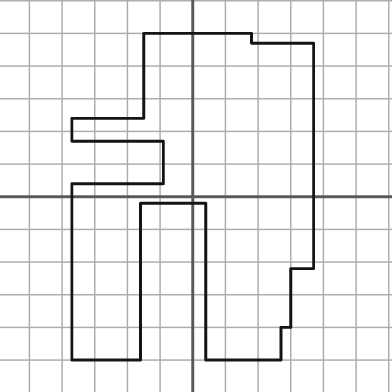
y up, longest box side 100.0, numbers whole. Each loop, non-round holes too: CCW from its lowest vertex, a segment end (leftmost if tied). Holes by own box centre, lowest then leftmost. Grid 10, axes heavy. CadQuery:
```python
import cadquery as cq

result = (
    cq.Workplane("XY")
    .moveTo(-37.0, -50.0)
    .lineTo(-16.0, -50.0)
    .lineTo(-16.0, -2.0)
    .lineTo(4.0, -2.0)
    .lineTo(4.0, -50.0)
    .lineTo(27.0, -50.0)
    .lineTo(27.0, -40.0)
    .lineTo(30.0, -40.0)
    .lineTo(30.0, -22.0)
    .lineTo(37.0, -22.0)
    .lineTo(37.0, 47.0)
    .lineTo(18.0, 47.0)
    .lineTo(18.0, 50.0)
    .lineTo(-15.0, 50.0)
    .lineTo(-15.0, 24.0)
    .lineTo(-37.0, 24.0)
    .lineTo(-37.0, 17.0)
    .lineTo(-9.0, 17.0)
    .lineTo(-9.0, 4.0)
    .lineTo(-37.0, 4.0)
    .close()
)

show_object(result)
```